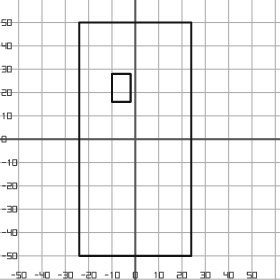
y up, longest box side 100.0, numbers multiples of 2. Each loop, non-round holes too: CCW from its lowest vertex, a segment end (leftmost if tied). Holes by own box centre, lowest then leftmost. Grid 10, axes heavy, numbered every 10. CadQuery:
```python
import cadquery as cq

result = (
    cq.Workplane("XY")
    .moveTo(-24.0, -50.0)
    .lineTo(24.0, -50.0)
    .lineTo(24.0, 50.0)
    .lineTo(-24.0, 50.0)
    .close()
    .moveTo(-10.0, 16.0)
    .lineTo(-2.0, 16.0)
    .lineTo(-2.0, 28.0)
    .lineTo(-10.0, 28.0)
    .close()
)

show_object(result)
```